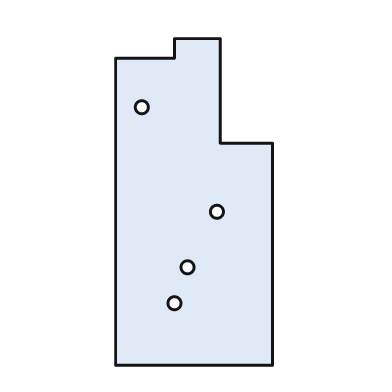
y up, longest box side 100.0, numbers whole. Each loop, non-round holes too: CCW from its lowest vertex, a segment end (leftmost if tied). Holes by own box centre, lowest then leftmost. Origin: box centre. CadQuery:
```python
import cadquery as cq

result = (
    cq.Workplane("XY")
    .moveTo(-24.0, -50.0)
    .lineTo(24.0, -50.0)
    .lineTo(24.0, 18.0)
    .lineTo(8.0, 18.0)
    .lineTo(8.0, 50.0)
    .lineTo(-6.0, 50.0)
    .lineTo(-6.0, 44.0)
    .lineTo(-24.0, 44.0)
    .close()
    .moveTo(-6.0, -31.0)
    .circle(2.0)
    .moveTo(-2.0, -20.0)
    .circle(2.0)
    .moveTo(7.0, -3.0)
    .circle(2.0)
    .moveTo(-16.0, 29.0)
    .circle(2.0)
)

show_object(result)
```